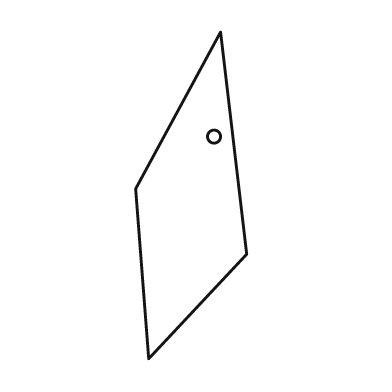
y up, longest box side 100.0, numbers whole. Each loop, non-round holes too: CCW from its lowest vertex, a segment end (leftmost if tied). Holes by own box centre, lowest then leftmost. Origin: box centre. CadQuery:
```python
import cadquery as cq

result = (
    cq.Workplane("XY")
    .moveTo(-13.0, -50.0)
    .lineTo(17.0, -18.0)
    .lineTo(9.0, 50.0)
    .lineTo(-17.0, 2.0)
    .close()
    .moveTo(7.0, 18.0)
    .circle(2.0)
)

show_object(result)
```